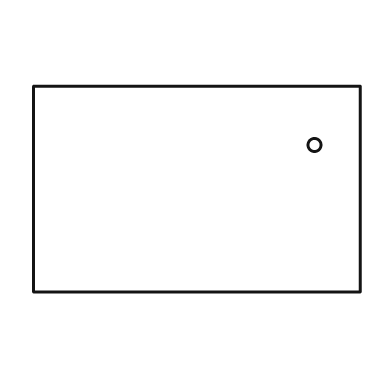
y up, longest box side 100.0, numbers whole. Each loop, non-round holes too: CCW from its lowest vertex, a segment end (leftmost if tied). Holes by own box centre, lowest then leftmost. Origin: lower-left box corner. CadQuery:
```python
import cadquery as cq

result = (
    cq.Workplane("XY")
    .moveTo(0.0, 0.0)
    .lineTo(100.0, 0.0)
    .lineTo(100.0, 63.0)
    .lineTo(0.0, 63.0)
    .close()
    .moveTo(86.0, 45.0)
    .circle(2.0)
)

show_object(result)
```